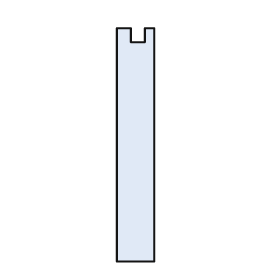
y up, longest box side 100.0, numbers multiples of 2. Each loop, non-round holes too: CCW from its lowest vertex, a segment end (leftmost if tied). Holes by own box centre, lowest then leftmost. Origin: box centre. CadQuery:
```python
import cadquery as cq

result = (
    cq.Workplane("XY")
    .moveTo(-8.0, -50.0)
    .lineTo(8.0, -50.0)
    .lineTo(8.0, 50.0)
    .lineTo(4.0, 50.0)
    .lineTo(4.0, 44.0)
    .lineTo(-2.0, 44.0)
    .lineTo(-2.0, 50.0)
    .lineTo(-8.0, 50.0)
    .close()
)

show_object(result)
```